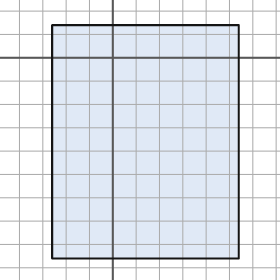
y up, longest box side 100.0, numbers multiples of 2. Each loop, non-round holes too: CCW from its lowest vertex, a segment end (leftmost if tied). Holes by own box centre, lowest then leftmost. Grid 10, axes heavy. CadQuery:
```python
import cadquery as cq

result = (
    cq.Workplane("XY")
    .moveTo(-26.0, -86.0)
    .lineTo(54.0, -86.0)
    .lineTo(54.0, 14.0)
    .lineTo(-26.0, 14.0)
    .close()
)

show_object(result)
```